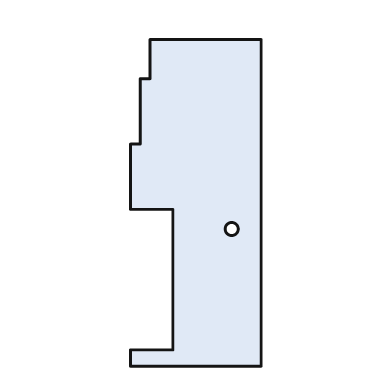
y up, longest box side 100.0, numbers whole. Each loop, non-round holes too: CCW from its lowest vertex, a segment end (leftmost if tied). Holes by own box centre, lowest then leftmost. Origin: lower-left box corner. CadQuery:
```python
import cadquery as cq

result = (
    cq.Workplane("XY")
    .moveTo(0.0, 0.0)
    .lineTo(40.0, 0.0)
    .lineTo(40.0, 100.0)
    .lineTo(6.0, 100.0)
    .lineTo(6.0, 88.0)
    .lineTo(3.0, 88.0)
    .lineTo(3.0, 68.0)
    .lineTo(0.0, 68.0)
    .lineTo(0.0, 48.0)
    .lineTo(13.0, 48.0)
    .lineTo(13.0, 5.0)
    .lineTo(0.0, 5.0)
    .close()
    .moveTo(31.0, 42.0)
    .circle(2.0)
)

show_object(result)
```